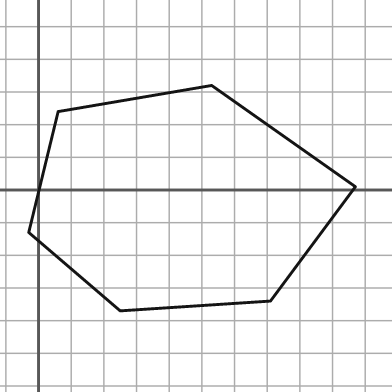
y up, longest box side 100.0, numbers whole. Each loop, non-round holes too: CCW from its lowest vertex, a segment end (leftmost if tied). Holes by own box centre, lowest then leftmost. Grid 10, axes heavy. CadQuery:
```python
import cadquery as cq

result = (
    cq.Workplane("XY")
    .moveTo(25.0, -37.0)
    .lineTo(71.0, -34.0)
    .lineTo(97.0, 1.0)
    .lineTo(53.0, 32.0)
    .lineTo(6.0, 24.0)
    .lineTo(-3.0, -13.0)
    .close()
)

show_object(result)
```